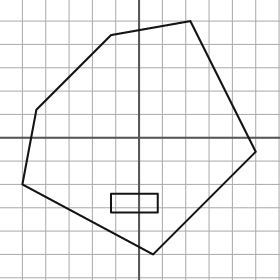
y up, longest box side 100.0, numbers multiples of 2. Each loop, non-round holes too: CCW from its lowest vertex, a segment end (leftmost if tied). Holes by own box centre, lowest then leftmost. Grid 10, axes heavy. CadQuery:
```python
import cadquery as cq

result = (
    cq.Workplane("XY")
    .moveTo(6.0, -50.0)
    .lineTo(50.0, -6.0)
    .lineTo(22.0, 50.0)
    .lineTo(-12.0, 44.0)
    .lineTo(-44.0, 12.0)
    .lineTo(-50.0, -20.0)
    .close()
    .moveTo(-12.0, -32.0)
    .lineTo(8.0, -32.0)
    .lineTo(8.0, -24.0)
    .lineTo(-12.0, -24.0)
    .close()
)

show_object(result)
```